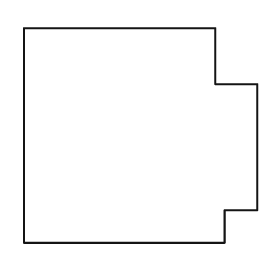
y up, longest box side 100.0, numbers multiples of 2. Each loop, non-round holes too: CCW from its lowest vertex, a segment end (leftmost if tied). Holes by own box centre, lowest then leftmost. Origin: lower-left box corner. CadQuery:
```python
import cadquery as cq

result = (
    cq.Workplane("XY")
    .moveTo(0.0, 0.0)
    .lineTo(86.0, 0.0)
    .lineTo(86.0, 14.0)
    .lineTo(100.0, 14.0)
    .lineTo(100.0, 68.0)
    .lineTo(82.0, 68.0)
    .lineTo(82.0, 92.0)
    .lineTo(0.0, 92.0)
    .close()
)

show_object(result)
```